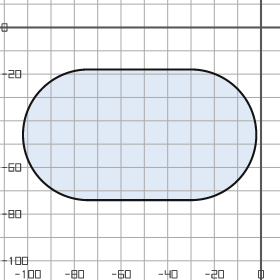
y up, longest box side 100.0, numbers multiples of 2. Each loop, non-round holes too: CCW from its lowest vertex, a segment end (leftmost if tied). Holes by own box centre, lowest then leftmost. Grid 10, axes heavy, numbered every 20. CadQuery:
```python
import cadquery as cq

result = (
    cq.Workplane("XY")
    .moveTo(-74.0, -74.0)
    .lineTo(-30.0, -74.0)
    .threePointArc((-2.0, -46.0), (-30.0, -18.0))
    .lineTo(-74.0, -18.0)
    .threePointArc((-102.0, -46.0), (-74.0, -74.0))
    .close()
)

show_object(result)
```